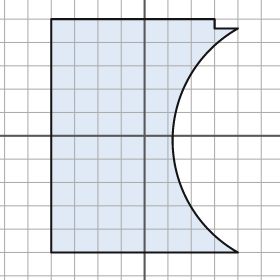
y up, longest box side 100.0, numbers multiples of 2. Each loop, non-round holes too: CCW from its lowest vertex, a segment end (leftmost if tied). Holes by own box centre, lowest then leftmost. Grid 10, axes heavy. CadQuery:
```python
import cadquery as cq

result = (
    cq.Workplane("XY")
    .moveTo(-40.0, -50.0)
    .lineTo(40.0, -50.0)
    .threePointArc((12.0, -2.0), (40.0, 46.0))
    .lineTo(30.0, 46.0)
    .lineTo(30.0, 50.0)
    .lineTo(-40.0, 50.0)
    .close()
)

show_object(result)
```